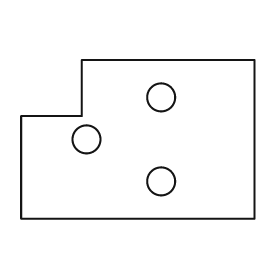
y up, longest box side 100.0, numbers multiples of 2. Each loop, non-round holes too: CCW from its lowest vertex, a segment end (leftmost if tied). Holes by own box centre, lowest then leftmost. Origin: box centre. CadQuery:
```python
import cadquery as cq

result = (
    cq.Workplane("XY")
    .moveTo(-50.0, -34.0)
    .lineTo(50.0, -34.0)
    .lineTo(50.0, 34.0)
    .lineTo(-24.0, 34.0)
    .lineTo(-24.0, 10.0)
    .lineTo(-50.0, 10.0)
    .close()
    .moveTo(10.0, -18.0)
    .circle(6.0)
    .moveTo(-22.0, 0.0)
    .circle(6.0)
    .moveTo(10.0, 18.0)
    .circle(6.0)
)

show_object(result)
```